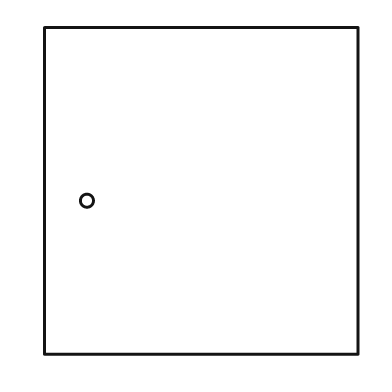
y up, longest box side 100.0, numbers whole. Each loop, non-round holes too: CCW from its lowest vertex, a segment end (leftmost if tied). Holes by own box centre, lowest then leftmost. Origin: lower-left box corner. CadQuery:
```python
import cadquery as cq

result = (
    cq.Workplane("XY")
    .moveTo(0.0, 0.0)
    .lineTo(96.0, 0.0)
    .lineTo(96.0, 100.0)
    .lineTo(0.0, 100.0)
    .close()
    .moveTo(13.0, 47.0)
    .circle(2.0)
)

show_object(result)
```